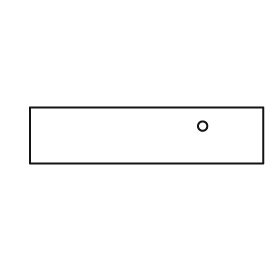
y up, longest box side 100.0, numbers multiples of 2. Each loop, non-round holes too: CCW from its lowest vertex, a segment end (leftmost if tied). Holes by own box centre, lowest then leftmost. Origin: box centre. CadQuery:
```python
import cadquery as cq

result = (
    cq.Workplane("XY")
    .moveTo(-50.0, -12.0)
    .lineTo(50.0, -12.0)
    .lineTo(50.0, 12.0)
    .lineTo(-50.0, 12.0)
    .close()
    .moveTo(24.0, 4.0)
    .circle(2.0)
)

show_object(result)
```